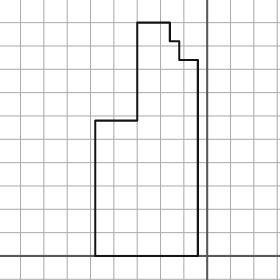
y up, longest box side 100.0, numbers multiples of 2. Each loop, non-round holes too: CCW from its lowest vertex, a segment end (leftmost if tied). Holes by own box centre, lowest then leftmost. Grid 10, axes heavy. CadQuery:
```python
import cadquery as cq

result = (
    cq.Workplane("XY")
    .moveTo(-48.0, 0.0)
    .lineTo(-4.0, 0.0)
    .lineTo(-4.0, 84.0)
    .lineTo(-12.0, 84.0)
    .lineTo(-12.0, 92.0)
    .lineTo(-16.0, 92.0)
    .lineTo(-16.0, 100.0)
    .lineTo(-30.0, 100.0)
    .lineTo(-30.0, 58.0)
    .lineTo(-48.0, 58.0)
    .close()
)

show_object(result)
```